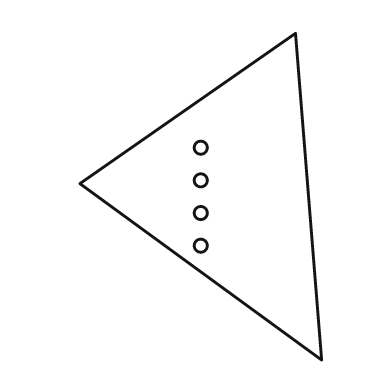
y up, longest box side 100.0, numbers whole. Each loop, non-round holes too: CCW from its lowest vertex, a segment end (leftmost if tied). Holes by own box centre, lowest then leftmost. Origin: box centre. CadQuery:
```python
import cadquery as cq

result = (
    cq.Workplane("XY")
    .moveTo(37.0, -50.0)
    .lineTo(29.0, 50.0)
    .lineTo(-37.0, 4.0)
    .close()
    .moveTo(0.0, -15.0)
    .circle(2.0)
    .moveTo(0.0, -5.0)
    .circle(2.0)
    .moveTo(0.0, 5.0)
    .circle(2.0)
    .moveTo(0.0, 15.0)
    .circle(2.0)
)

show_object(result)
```